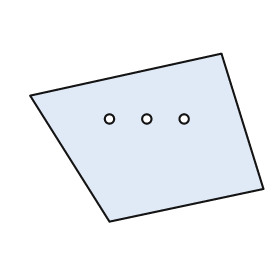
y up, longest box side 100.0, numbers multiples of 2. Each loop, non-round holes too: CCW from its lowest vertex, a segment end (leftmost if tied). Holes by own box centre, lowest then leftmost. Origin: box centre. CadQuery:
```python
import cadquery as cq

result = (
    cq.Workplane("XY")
    .moveTo(-16.0, -36.0)
    .lineTo(50.0, -22.0)
    .lineTo(32.0, 36.0)
    .lineTo(-50.0, 18.0)
    .close()
    .moveTo(-16.0, 8.0)
    .circle(2.0)
    .moveTo(0.0, 8.0)
    .circle(2.0)
    .moveTo(16.0, 8.0)
    .circle(2.0)
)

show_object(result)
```